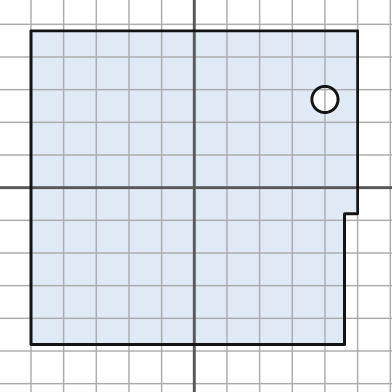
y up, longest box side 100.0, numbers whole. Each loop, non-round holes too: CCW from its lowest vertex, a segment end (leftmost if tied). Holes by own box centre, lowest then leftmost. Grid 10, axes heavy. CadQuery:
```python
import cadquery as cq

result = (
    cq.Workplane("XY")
    .moveTo(-50.0, -48.0)
    .lineTo(46.0, -48.0)
    .lineTo(46.0, -8.0)
    .lineTo(50.0, -8.0)
    .lineTo(50.0, 48.0)
    .lineTo(-50.0, 48.0)
    .close()
    .moveTo(40.0, 27.0)
    .circle(4.0)
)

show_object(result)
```